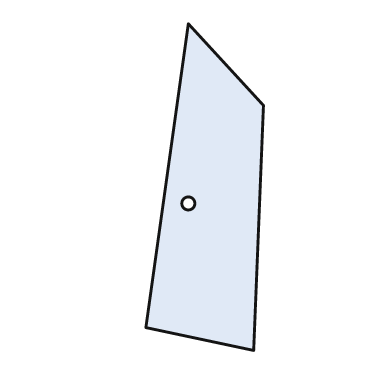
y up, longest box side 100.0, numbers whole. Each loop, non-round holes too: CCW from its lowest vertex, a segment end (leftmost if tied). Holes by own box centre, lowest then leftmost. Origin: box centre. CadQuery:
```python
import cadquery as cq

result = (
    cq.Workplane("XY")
    .moveTo(15.0, -50.0)
    .lineTo(18.0, 25.0)
    .lineTo(-5.0, 50.0)
    .lineTo(-18.0, -43.0)
    .close()
    .moveTo(-5.0, -5.0)
    .circle(2.0)
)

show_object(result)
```